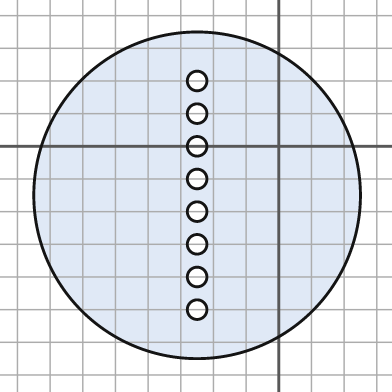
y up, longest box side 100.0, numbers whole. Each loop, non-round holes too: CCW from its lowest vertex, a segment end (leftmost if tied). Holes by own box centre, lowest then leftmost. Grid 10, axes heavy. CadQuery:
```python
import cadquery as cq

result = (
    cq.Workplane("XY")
    .moveTo(-25.0, -15.0)
    .circle(50.0)
    .moveTo(-25.0, -50.0)
    .circle(3.0)
    .moveTo(-25.0, -40.0)
    .circle(3.0)
    .moveTo(-25.0, -30.0)
    .circle(3.0)
    .moveTo(-25.0, -20.0)
    .circle(3.0)
    .moveTo(-25.0, -10.0)
    .circle(3.0)
    .moveTo(-25.0, 0.0)
    .circle(3.0)
    .moveTo(-25.0, 10.0)
    .circle(3.0)
    .moveTo(-25.0, 20.0)
    .circle(3.0)
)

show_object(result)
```